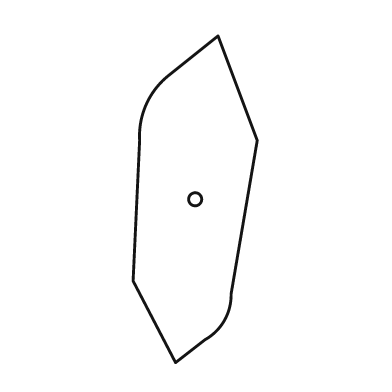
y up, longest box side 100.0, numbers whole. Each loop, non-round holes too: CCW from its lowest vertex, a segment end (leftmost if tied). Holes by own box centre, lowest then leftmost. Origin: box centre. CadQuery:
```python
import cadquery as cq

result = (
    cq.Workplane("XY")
    .moveTo(-6.0, -50.0)
    .lineTo(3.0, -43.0)
    .threePointArc((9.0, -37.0), (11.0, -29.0))
    .lineTo(19.0, 18.0)
    .lineTo(7.0, 50.0)
    .lineTo(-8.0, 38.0)
    .threePointArc((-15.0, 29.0), (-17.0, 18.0))
    .lineTo(-19.0, -25.0)
    .close()
    .moveTo(0.0, 0.0)
    .circle(2.0)
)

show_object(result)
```